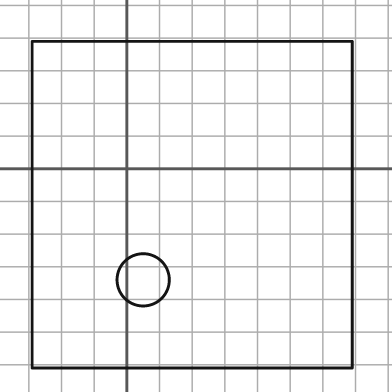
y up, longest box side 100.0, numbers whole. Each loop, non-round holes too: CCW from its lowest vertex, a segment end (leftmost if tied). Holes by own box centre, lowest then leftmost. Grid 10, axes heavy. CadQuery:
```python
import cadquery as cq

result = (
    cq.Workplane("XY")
    .moveTo(-29.0, -61.0)
    .lineTo(69.0, -61.0)
    .lineTo(69.0, 39.0)
    .lineTo(-29.0, 39.0)
    .close()
    .moveTo(5.0, -34.0)
    .circle(8.0)
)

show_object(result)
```